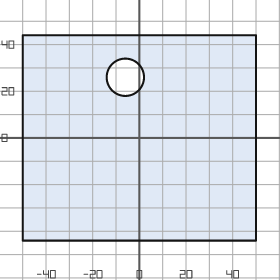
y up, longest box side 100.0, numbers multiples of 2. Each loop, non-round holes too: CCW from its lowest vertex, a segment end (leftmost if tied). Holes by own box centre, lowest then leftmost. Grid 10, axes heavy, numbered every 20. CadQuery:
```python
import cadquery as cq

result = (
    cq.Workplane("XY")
    .moveTo(-50.0, -44.0)
    .lineTo(50.0, -44.0)
    .lineTo(50.0, 44.0)
    .lineTo(-50.0, 44.0)
    .close()
    .moveTo(-6.0, 26.0)
    .circle(8.0)
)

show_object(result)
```